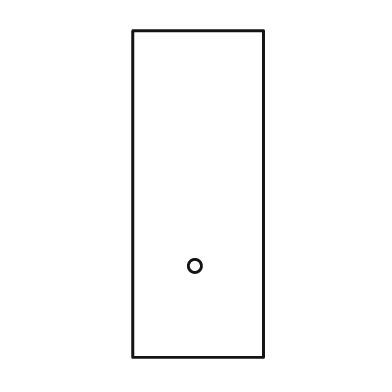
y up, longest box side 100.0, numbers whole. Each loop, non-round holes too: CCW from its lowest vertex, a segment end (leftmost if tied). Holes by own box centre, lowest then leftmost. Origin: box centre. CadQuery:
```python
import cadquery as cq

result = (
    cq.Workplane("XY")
    .moveTo(-20.0, -50.0)
    .lineTo(20.0, -50.0)
    .lineTo(20.0, 50.0)
    .lineTo(-20.0, 50.0)
    .close()
    .moveTo(-1.0, -22.0)
    .circle(2.0)
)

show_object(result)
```